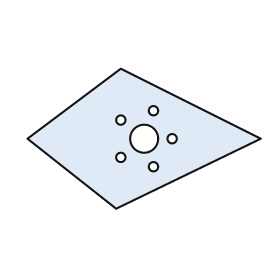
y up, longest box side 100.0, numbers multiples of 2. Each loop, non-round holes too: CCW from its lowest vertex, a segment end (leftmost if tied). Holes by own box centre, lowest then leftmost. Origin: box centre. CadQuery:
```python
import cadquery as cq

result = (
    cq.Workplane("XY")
    .moveTo(-12.0, -30.0)
    .lineTo(50.0, 0.0)
    .lineTo(-10.0, 30.0)
    .lineTo(-50.0, 0.0)
    .close()
    .moveTo(4.0, -12.0)
    .circle(2.0)
    .moveTo(-10.0, -8.0)
    .circle(2.0)
    .moveTo(0.0, 0.0)
    .circle(6.0)
    .moveTo(12.0, 0.0)
    .circle(2.0)
    .moveTo(-10.0, 8.0)
    .circle(2.0)
    .moveTo(4.0, 12.0)
    .circle(2.0)
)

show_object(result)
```